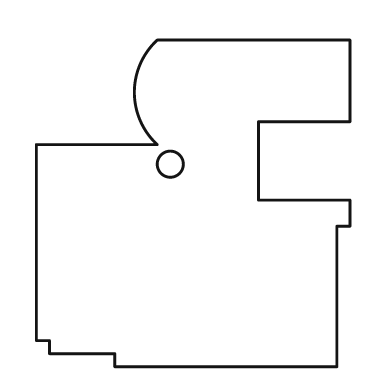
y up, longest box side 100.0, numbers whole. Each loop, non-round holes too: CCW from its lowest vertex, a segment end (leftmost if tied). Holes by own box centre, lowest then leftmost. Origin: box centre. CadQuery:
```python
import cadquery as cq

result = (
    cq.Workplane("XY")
    .moveTo(-24.0, -50.0)
    .lineTo(44.0, -50.0)
    .lineTo(44.0, -7.0)
    .lineTo(48.0, -7.0)
    .lineTo(48.0, 1.0)
    .lineTo(20.0, 1.0)
    .lineTo(20.0, 25.0)
    .lineTo(48.0, 25.0)
    .lineTo(48.0, 50.0)
    .lineTo(-11.0, 50.0)
    .threePointArc((-18.0, 34.0), (-11.0, 18.0))
    .lineTo(-48.0, 18.0)
    .lineTo(-48.0, -42.0)
    .lineTo(-44.0, -42.0)
    .lineTo(-44.0, -46.0)
    .lineTo(-24.0, -46.0)
    .close()
    .moveTo(-7.0, 12.0)
    .circle(4.0)
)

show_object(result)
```